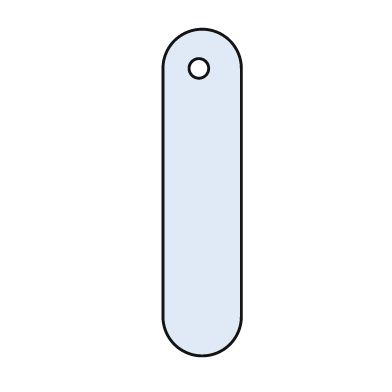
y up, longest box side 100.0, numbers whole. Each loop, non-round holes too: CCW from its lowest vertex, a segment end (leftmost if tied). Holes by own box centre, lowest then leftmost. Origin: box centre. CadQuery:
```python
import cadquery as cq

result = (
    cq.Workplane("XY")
    .moveTo(-12.0, -38.0)
    .threePointArc((0.0, -50.0), (12.0, -38.0))
    .lineTo(12.0, 38.0)
    .threePointArc((0.0, 50.0), (-12.0, 38.0))
    .close()
    .moveTo(-1.0, 38.0)
    .circle(3.0)
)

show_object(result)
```